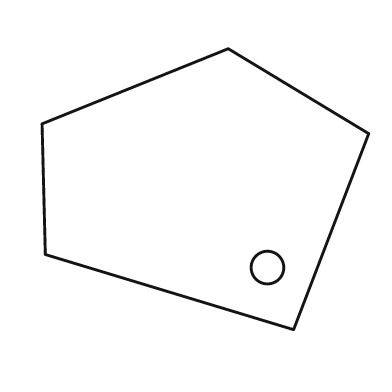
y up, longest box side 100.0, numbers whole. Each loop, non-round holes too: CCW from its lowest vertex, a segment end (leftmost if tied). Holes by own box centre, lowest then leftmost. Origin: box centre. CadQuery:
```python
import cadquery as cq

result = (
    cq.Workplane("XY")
    .moveTo(27.0, -43.0)
    .lineTo(50.0, 17.0)
    .lineTo(7.0, 43.0)
    .lineTo(-50.0, 20.0)
    .lineTo(-49.0, -20.0)
    .close()
    .moveTo(19.0, -24.0)
    .circle(5.0)
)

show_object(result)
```